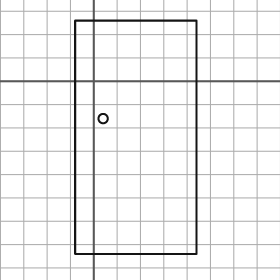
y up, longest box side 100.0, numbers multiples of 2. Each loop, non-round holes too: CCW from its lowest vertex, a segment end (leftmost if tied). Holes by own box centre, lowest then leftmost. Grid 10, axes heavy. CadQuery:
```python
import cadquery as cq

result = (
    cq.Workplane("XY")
    .moveTo(-8.0, -74.0)
    .lineTo(44.0, -74.0)
    .lineTo(44.0, 26.0)
    .lineTo(-8.0, 26.0)
    .close()
    .moveTo(4.0, -16.0)
    .circle(2.0)
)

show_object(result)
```